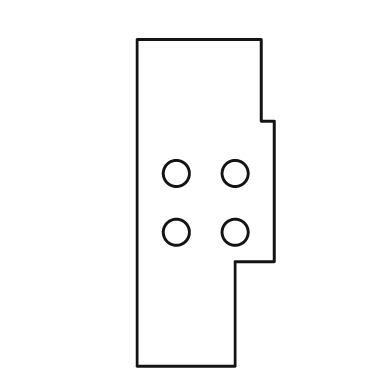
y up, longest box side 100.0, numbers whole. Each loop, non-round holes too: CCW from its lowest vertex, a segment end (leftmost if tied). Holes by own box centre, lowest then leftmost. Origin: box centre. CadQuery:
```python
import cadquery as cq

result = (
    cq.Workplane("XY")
    .moveTo(-21.0, -50.0)
    .lineTo(9.0, -50.0)
    .lineTo(9.0, -18.0)
    .lineTo(21.0, -18.0)
    .lineTo(21.0, 25.0)
    .lineTo(17.0, 25.0)
    .lineTo(17.0, 50.0)
    .lineTo(-21.0, 50.0)
    .close()
    .moveTo(-9.0, -9.0)
    .circle(4.0)
    .moveTo(9.0, -9.0)
    .circle(4.0)
    .moveTo(-9.0, 9.0)
    .circle(4.0)
    .moveTo(9.0, 9.0)
    .circle(4.0)
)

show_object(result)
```